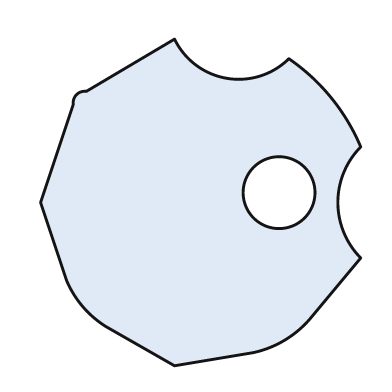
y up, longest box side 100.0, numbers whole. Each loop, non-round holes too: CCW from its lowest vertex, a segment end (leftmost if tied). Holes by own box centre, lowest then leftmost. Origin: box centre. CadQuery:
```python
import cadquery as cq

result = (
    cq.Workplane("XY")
    .moveTo(-8.0, -50.0)
    .lineTo(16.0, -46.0)
    .threePointArc((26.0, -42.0), (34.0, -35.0))
    .lineTo(49.0, -17.0)
    .threePointArc((42.0, 0.0), (49.0, 17.0))
    .threePointArc((40.0, 32.0), (27.0, 44.0))
    .threePointArc((8.0, 38.0), (-8.0, 50.0))
    .lineTo(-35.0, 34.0)
    .threePointArc((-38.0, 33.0), (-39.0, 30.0))
    .lineTo(-49.0, 0.0)
    .lineTo(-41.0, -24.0)
    .threePointArc((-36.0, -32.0), (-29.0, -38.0))
    .close()
    .moveTo(24.0, 3.0)
    .circle(11.0)
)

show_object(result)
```